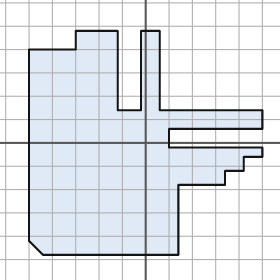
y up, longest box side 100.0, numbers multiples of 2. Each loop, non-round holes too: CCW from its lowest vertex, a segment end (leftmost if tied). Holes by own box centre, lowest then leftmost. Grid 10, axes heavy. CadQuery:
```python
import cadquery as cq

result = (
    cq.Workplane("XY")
    .moveTo(-44.0, -48.0)
    .lineTo(14.0, -48.0)
    .lineTo(14.0, -18.0)
    .lineTo(34.0, -18.0)
    .lineTo(34.0, -12.0)
    .lineTo(42.0, -12.0)
    .lineTo(42.0, -6.0)
    .lineTo(50.0, -6.0)
    .lineTo(50.0, -2.0)
    .lineTo(10.0, -2.0)
    .lineTo(10.0, 6.0)
    .lineTo(50.0, 6.0)
    .lineTo(50.0, 14.0)
    .lineTo(6.0, 14.0)
    .lineTo(6.0, 48.0)
    .lineTo(-2.0, 48.0)
    .lineTo(-2.0, 14.0)
    .lineTo(-12.0, 14.0)
    .lineTo(-12.0, 48.0)
    .lineTo(-30.0, 48.0)
    .lineTo(-30.0, 40.0)
    .lineTo(-50.0, 40.0)
    .lineTo(-50.0, -42.0)
    .close()
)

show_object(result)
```